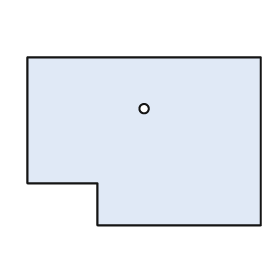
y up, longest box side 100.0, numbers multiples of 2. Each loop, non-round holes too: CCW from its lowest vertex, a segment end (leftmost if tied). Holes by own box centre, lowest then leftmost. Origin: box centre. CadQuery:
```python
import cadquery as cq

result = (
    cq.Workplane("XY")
    .moveTo(-20.0, -36.0)
    .lineTo(50.0, -36.0)
    .lineTo(50.0, 36.0)
    .lineTo(-50.0, 36.0)
    .lineTo(-50.0, -18.0)
    .lineTo(-20.0, -18.0)
    .close()
    .moveTo(0.0, 14.0)
    .circle(2.0)
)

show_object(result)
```